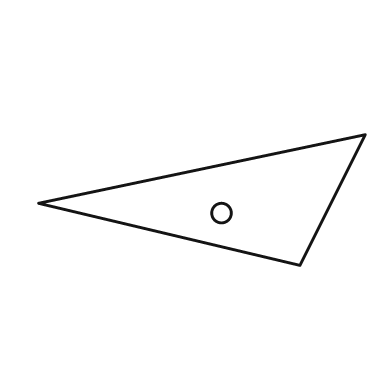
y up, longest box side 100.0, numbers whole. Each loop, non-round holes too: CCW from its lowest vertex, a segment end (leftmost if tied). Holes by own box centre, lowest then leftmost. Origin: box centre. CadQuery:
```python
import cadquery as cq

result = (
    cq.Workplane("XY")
    .moveTo(30.0, -20.0)
    .lineTo(50.0, 20.0)
    .lineTo(-50.0, -1.0)
    .close()
    .moveTo(6.0, -4.0)
    .circle(3.0)
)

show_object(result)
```